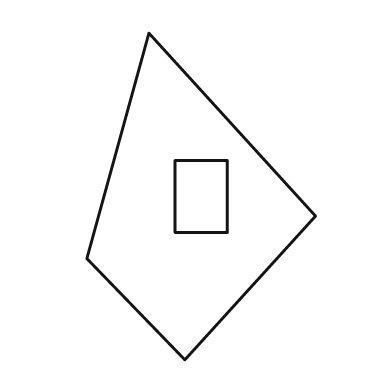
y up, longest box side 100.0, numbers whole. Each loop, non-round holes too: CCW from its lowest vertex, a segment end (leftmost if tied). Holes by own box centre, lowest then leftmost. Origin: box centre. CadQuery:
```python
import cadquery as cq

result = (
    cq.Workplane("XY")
    .moveTo(-5.0, -50.0)
    .lineTo(35.0, -6.0)
    .lineTo(-16.0, 50.0)
    .lineTo(-35.0, -19.0)
    .close()
    .moveTo(-8.0, -11.0)
    .lineTo(8.0, -11.0)
    .lineTo(8.0, 11.0)
    .lineTo(-8.0, 11.0)
    .close()
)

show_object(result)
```